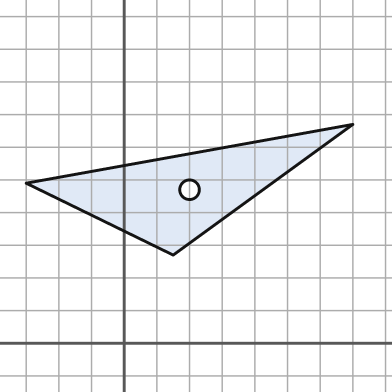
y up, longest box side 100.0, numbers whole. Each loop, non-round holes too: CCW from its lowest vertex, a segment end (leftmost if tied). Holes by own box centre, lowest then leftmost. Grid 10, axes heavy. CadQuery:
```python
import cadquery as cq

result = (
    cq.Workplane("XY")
    .moveTo(15.0, 27.0)
    .lineTo(70.0, 67.0)
    .lineTo(-30.0, 49.0)
    .close()
    .moveTo(20.0, 47.0)
    .circle(3.0)
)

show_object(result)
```